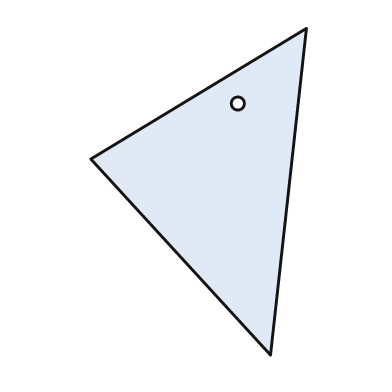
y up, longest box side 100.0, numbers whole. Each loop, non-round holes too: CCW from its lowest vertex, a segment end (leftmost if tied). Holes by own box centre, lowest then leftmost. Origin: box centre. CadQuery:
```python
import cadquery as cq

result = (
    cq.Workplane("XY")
    .moveTo(22.0, -50.0)
    .lineTo(33.0, 50.0)
    .lineTo(-33.0, 10.0)
    .close()
    .moveTo(12.0, 27.0)
    .circle(2.0)
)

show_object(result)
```